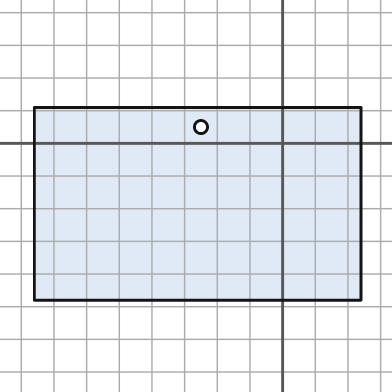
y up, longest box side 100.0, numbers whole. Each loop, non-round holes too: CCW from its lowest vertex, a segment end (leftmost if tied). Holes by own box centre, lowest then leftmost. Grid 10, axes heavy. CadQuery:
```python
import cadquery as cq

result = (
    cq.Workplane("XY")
    .moveTo(-76.0, -48.0)
    .lineTo(24.0, -48.0)
    .lineTo(24.0, 11.0)
    .lineTo(-76.0, 11.0)
    .close()
    .moveTo(-25.0, 5.0)
    .circle(2.0)
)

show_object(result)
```